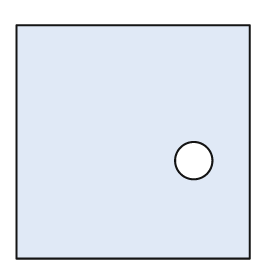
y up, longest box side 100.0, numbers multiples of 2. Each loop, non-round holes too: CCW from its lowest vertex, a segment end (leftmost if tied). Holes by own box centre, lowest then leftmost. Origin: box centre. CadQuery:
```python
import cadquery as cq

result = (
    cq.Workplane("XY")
    .moveTo(-50.0, -50.0)
    .lineTo(50.0, -50.0)
    .lineTo(50.0, 50.0)
    .lineTo(-50.0, 50.0)
    .close()
    .moveTo(26.0, -8.0)
    .circle(8.0)
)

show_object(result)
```